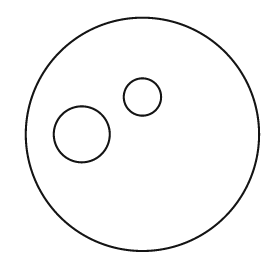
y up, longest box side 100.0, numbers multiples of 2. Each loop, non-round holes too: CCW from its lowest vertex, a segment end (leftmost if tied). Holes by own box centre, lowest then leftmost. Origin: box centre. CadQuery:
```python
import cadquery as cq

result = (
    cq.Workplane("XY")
    .moveTo(0.0, 0.0)
    .circle(50.0)
    .moveTo(-26.0, 0.0)
    .circle(12.0)
    .moveTo(0.0, 16.0)
    .circle(8.0)
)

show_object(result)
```